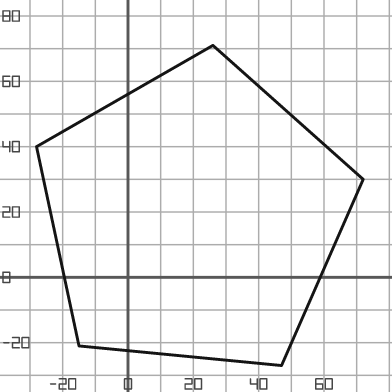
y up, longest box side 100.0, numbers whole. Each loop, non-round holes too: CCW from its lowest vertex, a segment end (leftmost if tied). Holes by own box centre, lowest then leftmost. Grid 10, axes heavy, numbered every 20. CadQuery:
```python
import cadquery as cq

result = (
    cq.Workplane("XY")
    .moveTo(47.0, -27.0)
    .lineTo(72.0, 30.0)
    .lineTo(26.0, 71.0)
    .lineTo(-28.0, 40.0)
    .lineTo(-15.0, -21.0)
    .close()
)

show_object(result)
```